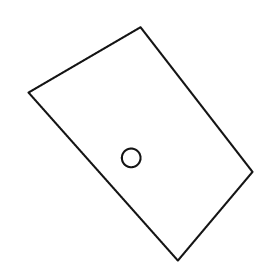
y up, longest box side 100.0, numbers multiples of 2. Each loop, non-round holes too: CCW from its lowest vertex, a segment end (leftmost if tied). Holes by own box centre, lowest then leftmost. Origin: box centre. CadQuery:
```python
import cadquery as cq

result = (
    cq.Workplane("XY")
    .moveTo(16.0, -50.0)
    .lineTo(48.0, -12.0)
    .lineTo(0.0, 50.0)
    .lineTo(-48.0, 22.0)
    .close()
    .moveTo(-4.0, -6.0)
    .circle(4.0)
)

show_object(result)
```